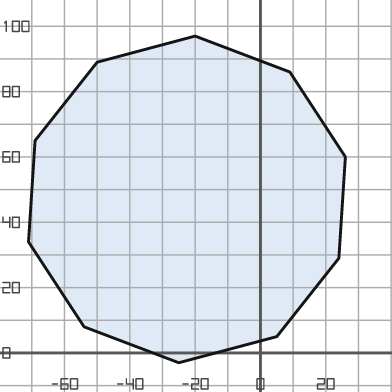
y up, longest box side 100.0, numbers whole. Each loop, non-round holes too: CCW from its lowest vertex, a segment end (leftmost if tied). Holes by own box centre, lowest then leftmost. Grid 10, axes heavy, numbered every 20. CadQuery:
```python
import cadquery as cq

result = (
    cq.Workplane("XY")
    .moveTo(-25.0, -3.0)
    .lineTo(5.0, 5.0)
    .lineTo(24.0, 29.0)
    .lineTo(26.0, 60.0)
    .lineTo(9.0, 86.0)
    .lineTo(-20.0, 97.0)
    .lineTo(-50.0, 89.0)
    .lineTo(-69.0, 65.0)
    .lineTo(-71.0, 34.0)
    .lineTo(-54.0, 8.0)
    .close()
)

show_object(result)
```